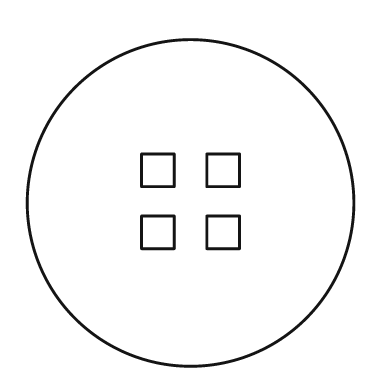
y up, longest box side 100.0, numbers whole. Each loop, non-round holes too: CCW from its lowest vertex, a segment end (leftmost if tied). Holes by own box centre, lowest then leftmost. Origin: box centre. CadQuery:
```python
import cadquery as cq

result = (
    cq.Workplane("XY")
    .moveTo(0.0, 0.0)
    .circle(50.0)
    .moveTo(-15.0, -14.0)
    .lineTo(-5.0, -14.0)
    .lineTo(-5.0, -4.0)
    .lineTo(-15.0, -4.0)
    .close()
    .moveTo(5.0, -14.0)
    .lineTo(15.0, -14.0)
    .lineTo(15.0, -4.0)
    .lineTo(5.0, -4.0)
    .close()
    .moveTo(-15.0, 5.0)
    .lineTo(-5.0, 5.0)
    .lineTo(-5.0, 15.0)
    .lineTo(-15.0, 15.0)
    .close()
    .moveTo(5.0, 5.0)
    .lineTo(15.0, 5.0)
    .lineTo(15.0, 15.0)
    .lineTo(5.0, 15.0)
    .close()
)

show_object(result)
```